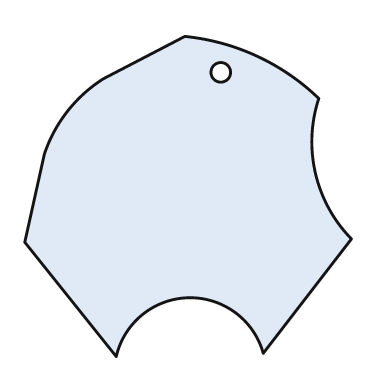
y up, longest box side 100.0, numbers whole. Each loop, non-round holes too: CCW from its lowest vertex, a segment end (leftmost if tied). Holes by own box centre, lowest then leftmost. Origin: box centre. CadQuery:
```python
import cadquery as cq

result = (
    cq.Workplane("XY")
    .moveTo(-22.0, -49.0)
    .threePointArc((0.0, -31.0), (23.0, -48.0))
    .lineTo(50.0, -13.0)
    .threePointArc((39.0, 7.0), (40.0, 30.0))
    .threePointArc((21.0, 43.0), (-1.0, 49.0))
    .lineTo(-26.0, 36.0)
    .threePointArc((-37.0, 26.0), (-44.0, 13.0))
    .lineTo(-50.0, -14.0)
    .close()
    .moveTo(10.0, 38.0)
    .circle(3.0)
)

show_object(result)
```